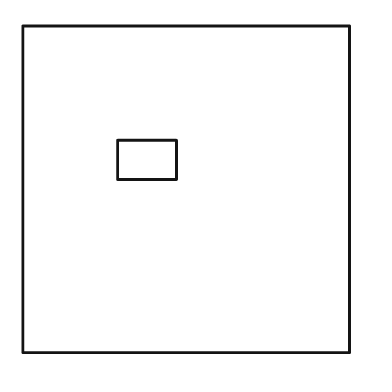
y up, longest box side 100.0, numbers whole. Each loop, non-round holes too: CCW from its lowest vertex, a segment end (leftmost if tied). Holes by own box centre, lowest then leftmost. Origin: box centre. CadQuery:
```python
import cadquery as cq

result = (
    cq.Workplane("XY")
    .moveTo(-50.0, -50.0)
    .lineTo(50.0, -50.0)
    .lineTo(50.0, 50.0)
    .lineTo(-50.0, 50.0)
    .close()
    .moveTo(-21.0, 3.0)
    .lineTo(-3.0, 3.0)
    .lineTo(-3.0, 15.0)
    .lineTo(-21.0, 15.0)
    .close()
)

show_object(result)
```